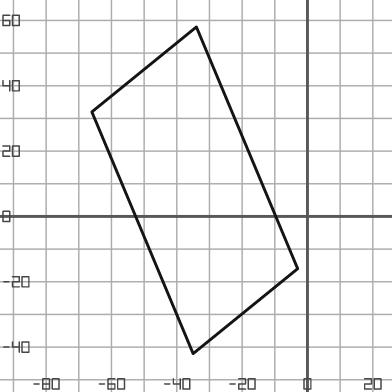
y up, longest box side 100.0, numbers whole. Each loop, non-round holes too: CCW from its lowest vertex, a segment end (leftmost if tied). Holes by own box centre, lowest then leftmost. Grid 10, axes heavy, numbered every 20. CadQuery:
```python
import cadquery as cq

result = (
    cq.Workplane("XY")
    .moveTo(-35.0, -42.0)
    .lineTo(-3.0, -16.0)
    .lineTo(-34.0, 58.0)
    .lineTo(-66.0, 32.0)
    .close()
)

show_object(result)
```